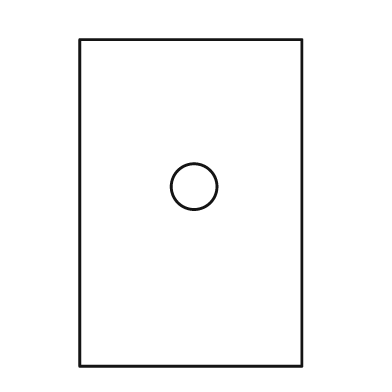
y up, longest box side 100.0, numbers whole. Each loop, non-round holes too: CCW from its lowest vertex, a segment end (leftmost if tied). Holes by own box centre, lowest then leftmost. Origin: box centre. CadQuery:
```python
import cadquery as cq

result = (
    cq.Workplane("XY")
    .moveTo(-34.0, -50.0)
    .lineTo(34.0, -50.0)
    .lineTo(34.0, 50.0)
    .lineTo(-34.0, 50.0)
    .close()
    .moveTo(1.0, 5.0)
    .circle(7.0)
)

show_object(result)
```